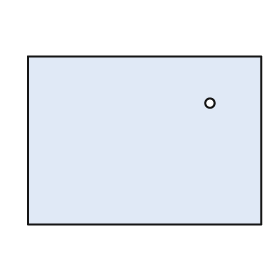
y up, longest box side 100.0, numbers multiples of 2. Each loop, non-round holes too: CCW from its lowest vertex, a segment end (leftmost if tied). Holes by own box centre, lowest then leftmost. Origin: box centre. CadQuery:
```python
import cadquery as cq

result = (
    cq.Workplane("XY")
    .moveTo(-50.0, -36.0)
    .lineTo(50.0, -36.0)
    .lineTo(50.0, 36.0)
    .lineTo(-50.0, 36.0)
    .close()
    .moveTo(28.0, 16.0)
    .circle(2.0)
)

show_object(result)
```